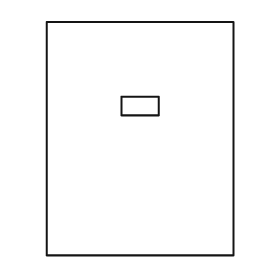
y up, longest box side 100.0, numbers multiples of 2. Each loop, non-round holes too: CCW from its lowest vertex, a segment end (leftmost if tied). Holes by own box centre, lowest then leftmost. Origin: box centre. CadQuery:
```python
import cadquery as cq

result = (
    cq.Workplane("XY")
    .moveTo(-40.0, -50.0)
    .lineTo(40.0, -50.0)
    .lineTo(40.0, 50.0)
    .lineTo(-40.0, 50.0)
    .close()
    .moveTo(-8.0, 10.0)
    .lineTo(8.0, 10.0)
    .lineTo(8.0, 18.0)
    .lineTo(-8.0, 18.0)
    .close()
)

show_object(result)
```